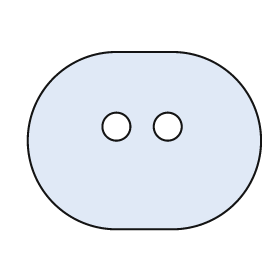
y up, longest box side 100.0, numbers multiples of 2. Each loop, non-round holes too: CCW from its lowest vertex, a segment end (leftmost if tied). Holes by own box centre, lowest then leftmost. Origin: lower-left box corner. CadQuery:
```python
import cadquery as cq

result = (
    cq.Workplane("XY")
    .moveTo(38.0, 0.0)
    .lineTo(62.0, 0.0)
    .threePointArc((100.0, 38.0), (62.0, 76.0))
    .lineTo(38.0, 76.0)
    .threePointArc((0.0, 38.0), (38.0, 0.0))
    .close()
    .moveTo(38.0, 44.0)
    .circle(6.0)
    .moveTo(60.0, 44.0)
    .circle(6.0)
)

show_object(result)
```